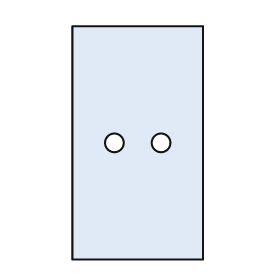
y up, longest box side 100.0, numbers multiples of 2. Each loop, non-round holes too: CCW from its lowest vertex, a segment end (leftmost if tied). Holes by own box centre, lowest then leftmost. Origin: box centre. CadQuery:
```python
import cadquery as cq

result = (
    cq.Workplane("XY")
    .moveTo(-28.0, -50.0)
    .lineTo(28.0, -50.0)
    .lineTo(28.0, 50.0)
    .lineTo(-28.0, 50.0)
    .close()
    .moveTo(-10.0, 0.0)
    .circle(4.0)
    .moveTo(10.0, 0.0)
    .circle(4.0)
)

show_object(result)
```